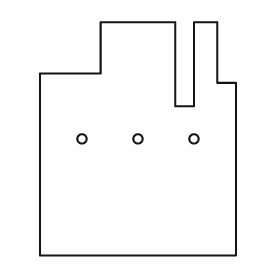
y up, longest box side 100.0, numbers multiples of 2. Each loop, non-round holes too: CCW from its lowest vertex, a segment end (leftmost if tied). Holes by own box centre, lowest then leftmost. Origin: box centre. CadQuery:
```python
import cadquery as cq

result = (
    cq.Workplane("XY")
    .moveTo(-42.0, -50.0)
    .lineTo(42.0, -50.0)
    .lineTo(42.0, 24.0)
    .lineTo(34.0, 24.0)
    .lineTo(34.0, 50.0)
    .lineTo(24.0, 50.0)
    .lineTo(24.0, 14.0)
    .lineTo(16.0, 14.0)
    .lineTo(16.0, 50.0)
    .lineTo(-16.0, 50.0)
    .lineTo(-16.0, 28.0)
    .lineTo(-42.0, 28.0)
    .close()
    .moveTo(-24.0, 0.0)
    .circle(2.0)
    .moveTo(0.0, 0.0)
    .circle(2.0)
    .moveTo(24.0, 0.0)
    .circle(2.0)
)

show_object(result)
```